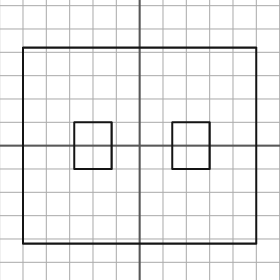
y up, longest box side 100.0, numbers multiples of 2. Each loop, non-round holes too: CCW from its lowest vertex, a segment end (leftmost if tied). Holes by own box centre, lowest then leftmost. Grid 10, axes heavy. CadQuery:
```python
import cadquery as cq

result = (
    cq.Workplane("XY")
    .moveTo(-50.0, -42.0)
    .lineTo(50.0, -42.0)
    .lineTo(50.0, 42.0)
    .lineTo(-50.0, 42.0)
    .close()
    .moveTo(-28.0, -10.0)
    .lineTo(-12.0, -10.0)
    .lineTo(-12.0, 10.0)
    .lineTo(-28.0, 10.0)
    .close()
    .moveTo(14.0, -10.0)
    .lineTo(30.0, -10.0)
    .lineTo(30.0, 10.0)
    .lineTo(14.0, 10.0)
    .close()
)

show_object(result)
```